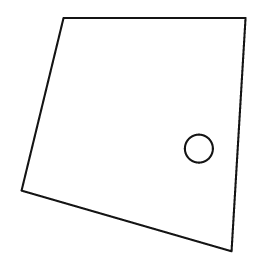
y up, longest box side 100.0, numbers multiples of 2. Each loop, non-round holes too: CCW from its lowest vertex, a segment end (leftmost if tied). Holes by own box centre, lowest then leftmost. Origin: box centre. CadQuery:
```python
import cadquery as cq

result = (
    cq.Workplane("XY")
    .moveTo(42.0, -50.0)
    .lineTo(48.0, 50.0)
    .lineTo(-30.0, 50.0)
    .lineTo(-48.0, -24.0)
    .close()
    .moveTo(28.0, -6.0)
    .circle(6.0)
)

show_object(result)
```